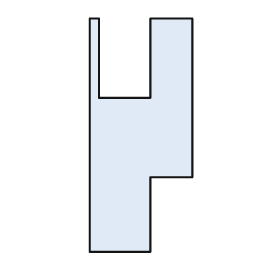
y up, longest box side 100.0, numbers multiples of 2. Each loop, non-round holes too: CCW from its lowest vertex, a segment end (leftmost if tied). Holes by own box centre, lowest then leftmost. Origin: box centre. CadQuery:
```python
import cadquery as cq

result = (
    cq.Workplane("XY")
    .moveTo(-22.0, -50.0)
    .lineTo(4.0, -50.0)
    .lineTo(4.0, -18.0)
    .lineTo(22.0, -18.0)
    .lineTo(22.0, 50.0)
    .lineTo(4.0, 50.0)
    .lineTo(4.0, 16.0)
    .lineTo(-18.0, 16.0)
    .lineTo(-18.0, 50.0)
    .lineTo(-22.0, 50.0)
    .close()
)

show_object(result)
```